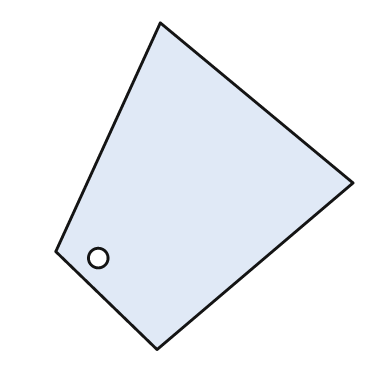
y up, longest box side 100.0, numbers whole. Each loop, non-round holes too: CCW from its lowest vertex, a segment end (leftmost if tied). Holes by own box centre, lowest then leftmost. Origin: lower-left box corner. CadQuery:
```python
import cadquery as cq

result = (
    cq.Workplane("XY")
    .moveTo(31.0, 0.0)
    .lineTo(91.0, 51.0)
    .lineTo(32.0, 100.0)
    .lineTo(0.0, 30.0)
    .close()
    .moveTo(13.0, 28.0)
    .circle(3.0)
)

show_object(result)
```